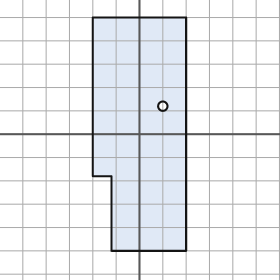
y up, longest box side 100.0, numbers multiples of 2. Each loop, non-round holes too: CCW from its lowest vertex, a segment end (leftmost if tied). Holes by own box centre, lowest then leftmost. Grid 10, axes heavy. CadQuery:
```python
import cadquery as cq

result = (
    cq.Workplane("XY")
    .moveTo(-12.0, -50.0)
    .lineTo(20.0, -50.0)
    .lineTo(20.0, 50.0)
    .lineTo(-20.0, 50.0)
    .lineTo(-20.0, -18.0)
    .lineTo(-12.0, -18.0)
    .close()
    .moveTo(10.0, 12.0)
    .circle(2.0)
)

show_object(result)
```